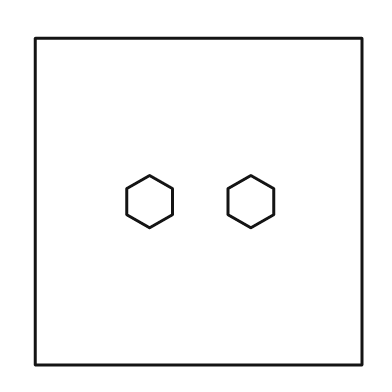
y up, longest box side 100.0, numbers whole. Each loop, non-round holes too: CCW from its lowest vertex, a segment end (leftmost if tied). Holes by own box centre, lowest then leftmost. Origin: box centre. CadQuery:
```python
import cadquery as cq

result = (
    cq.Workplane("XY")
    .moveTo(-50.0, -50.0)
    .lineTo(50.0, -50.0)
    .lineTo(50.0, 50.0)
    .lineTo(-50.0, 50.0)
    .close()
    .moveTo(-15.0, -8.0)
    .lineTo(-8.0, -4.0)
    .lineTo(-8.0, 4.0)
    .lineTo(-15.0, 8.0)
    .lineTo(-22.0, 4.0)
    .lineTo(-22.0, -4.0)
    .close()
    .moveTo(16.0, -8.0)
    .lineTo(23.0, -4.0)
    .lineTo(23.0, 4.0)
    .lineTo(16.0, 8.0)
    .lineTo(9.0, 4.0)
    .lineTo(9.0, -4.0)
    .close()
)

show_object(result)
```